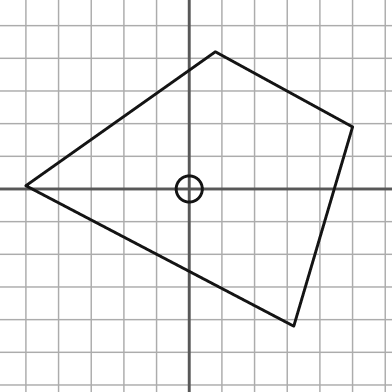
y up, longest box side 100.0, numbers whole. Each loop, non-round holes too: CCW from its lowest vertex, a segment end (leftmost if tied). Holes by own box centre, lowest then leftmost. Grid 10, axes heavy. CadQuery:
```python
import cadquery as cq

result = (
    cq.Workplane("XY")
    .moveTo(32.0, -42.0)
    .lineTo(50.0, 19.0)
    .lineTo(8.0, 42.0)
    .lineTo(-50.0, 1.0)
    .close()
    .moveTo(0.0, 0.0)
    .circle(4.0)
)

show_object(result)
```